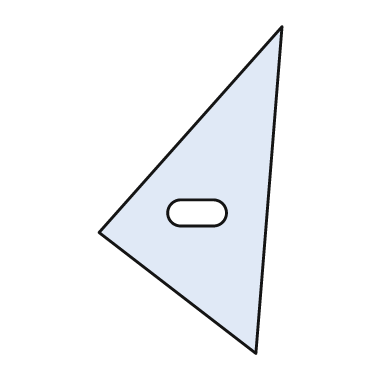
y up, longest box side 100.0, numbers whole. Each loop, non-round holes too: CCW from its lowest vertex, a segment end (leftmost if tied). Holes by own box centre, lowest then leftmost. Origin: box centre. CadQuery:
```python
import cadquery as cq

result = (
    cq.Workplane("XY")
    .moveTo(20.0, -50.0)
    .lineTo(28.0, 50.0)
    .lineTo(-28.0, -13.0)
    .close()
    .moveTo(-3.0, -11.0)
    .lineTo(7.0, -11.0)
    .threePointArc((11.0, -7.0), (7.0, -3.0))
    .lineTo(-3.0, -3.0)
    .threePointArc((-7.0, -7.0), (-3.0, -11.0))
    .close()
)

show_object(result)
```